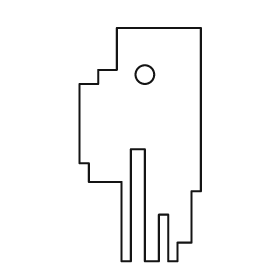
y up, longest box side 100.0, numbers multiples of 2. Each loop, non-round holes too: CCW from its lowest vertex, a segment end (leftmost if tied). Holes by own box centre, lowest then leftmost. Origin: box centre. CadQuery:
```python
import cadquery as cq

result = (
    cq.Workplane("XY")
    .moveTo(-8.0, -50.0)
    .lineTo(-4.0, -50.0)
    .lineTo(-4.0, -2.0)
    .lineTo(2.0, -2.0)
    .lineTo(2.0, -50.0)
    .lineTo(8.0, -50.0)
    .lineTo(8.0, -30.0)
    .lineTo(12.0, -30.0)
    .lineTo(12.0, -50.0)
    .lineTo(16.0, -50.0)
    .lineTo(16.0, -42.0)
    .lineTo(22.0, -42.0)
    .lineTo(22.0, -20.0)
    .lineTo(26.0, -20.0)
    .lineTo(26.0, 50.0)
    .lineTo(-10.0, 50.0)
    .lineTo(-10.0, 32.0)
    .lineTo(-18.0, 32.0)
    .lineTo(-18.0, 26.0)
    .lineTo(-26.0, 26.0)
    .lineTo(-26.0, -8.0)
    .lineTo(-22.0, -8.0)
    .lineTo(-22.0, -16.0)
    .lineTo(-8.0, -16.0)
    .close()
    .moveTo(2.0, 30.0)
    .circle(4.0)
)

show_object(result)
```